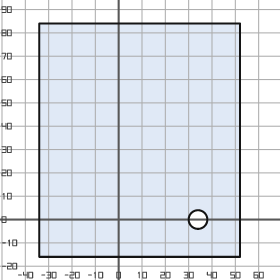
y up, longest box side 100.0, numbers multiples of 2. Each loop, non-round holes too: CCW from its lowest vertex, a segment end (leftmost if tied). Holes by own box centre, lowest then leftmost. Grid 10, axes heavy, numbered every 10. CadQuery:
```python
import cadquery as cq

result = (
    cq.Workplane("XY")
    .moveTo(-34.0, -16.0)
    .lineTo(52.0, -16.0)
    .lineTo(52.0, 84.0)
    .lineTo(-34.0, 84.0)
    .close()
    .moveTo(34.0, 0.0)
    .circle(4.0)
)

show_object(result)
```